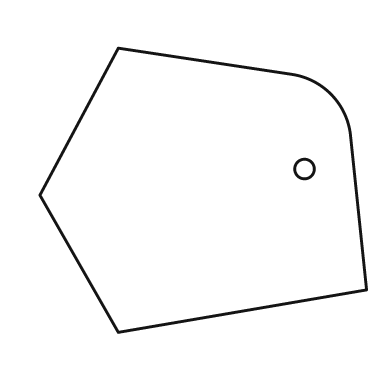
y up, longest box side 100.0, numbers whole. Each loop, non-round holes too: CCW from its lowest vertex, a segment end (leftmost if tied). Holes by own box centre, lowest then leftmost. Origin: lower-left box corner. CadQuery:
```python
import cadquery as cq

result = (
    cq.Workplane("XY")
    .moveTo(24.0, 0.0)
    .lineTo(100.0, 13.0)
    .lineTo(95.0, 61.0)
    .threePointArc((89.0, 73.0), (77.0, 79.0))
    .lineTo(24.0, 87.0)
    .lineTo(0.0, 42.0)
    .close()
    .moveTo(81.0, 50.0)
    .circle(3.0)
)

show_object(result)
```